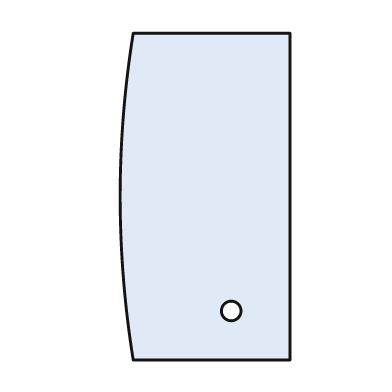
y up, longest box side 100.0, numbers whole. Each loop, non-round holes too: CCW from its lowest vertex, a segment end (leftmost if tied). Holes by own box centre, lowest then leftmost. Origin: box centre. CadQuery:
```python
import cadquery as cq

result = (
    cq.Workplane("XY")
    .moveTo(-22.0, -50.0)
    .lineTo(26.0, -50.0)
    .lineTo(26.0, 50.0)
    .lineTo(-22.0, 50.0)
    .threePointArc((-26.0, 0.0), (-22.0, -50.0))
    .close()
    .moveTo(8.0, -35.0)
    .circle(3.0)
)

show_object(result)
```